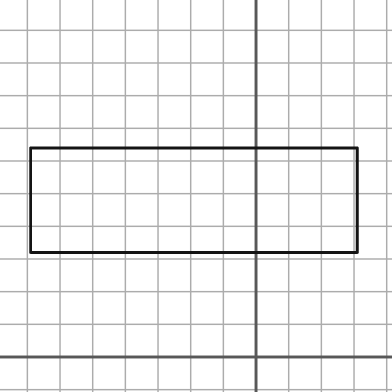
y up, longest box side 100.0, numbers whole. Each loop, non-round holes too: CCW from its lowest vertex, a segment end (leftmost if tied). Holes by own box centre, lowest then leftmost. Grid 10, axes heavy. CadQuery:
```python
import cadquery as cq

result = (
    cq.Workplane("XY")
    .moveTo(-69.0, 32.0)
    .lineTo(31.0, 32.0)
    .lineTo(31.0, 64.0)
    .lineTo(-69.0, 64.0)
    .close()
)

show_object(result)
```